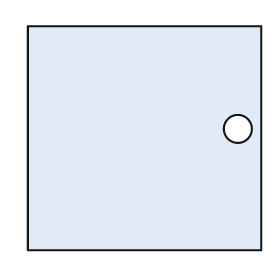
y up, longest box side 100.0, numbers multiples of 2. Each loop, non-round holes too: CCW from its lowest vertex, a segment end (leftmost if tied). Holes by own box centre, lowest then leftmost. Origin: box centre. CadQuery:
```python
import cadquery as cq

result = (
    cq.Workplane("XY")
    .moveTo(-50.0, -48.0)
    .lineTo(50.0, -48.0)
    .lineTo(50.0, 48.0)
    .lineTo(-50.0, 48.0)
    .close()
    .moveTo(40.0, 4.0)
    .circle(6.0)
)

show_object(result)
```